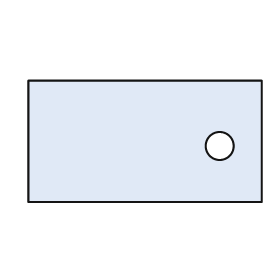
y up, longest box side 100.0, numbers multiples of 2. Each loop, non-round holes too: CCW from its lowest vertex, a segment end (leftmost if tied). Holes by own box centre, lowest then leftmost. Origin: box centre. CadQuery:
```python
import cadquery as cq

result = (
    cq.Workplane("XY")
    .moveTo(-50.0, -26.0)
    .lineTo(50.0, -26.0)
    .lineTo(50.0, 26.0)
    .lineTo(-50.0, 26.0)
    .close()
    .moveTo(32.0, -2.0)
    .circle(6.0)
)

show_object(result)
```